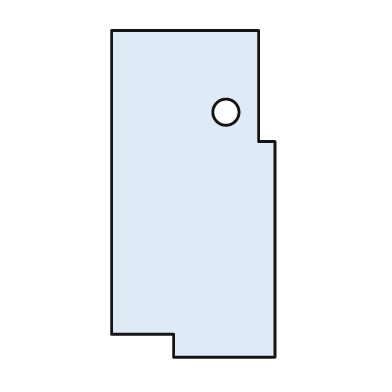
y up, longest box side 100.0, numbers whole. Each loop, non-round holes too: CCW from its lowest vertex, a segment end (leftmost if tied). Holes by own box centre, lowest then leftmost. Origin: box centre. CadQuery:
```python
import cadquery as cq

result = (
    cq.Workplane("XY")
    .moveTo(-6.0, -50.0)
    .lineTo(25.0, -50.0)
    .lineTo(25.0, 16.0)
    .lineTo(20.0, 16.0)
    .lineTo(20.0, 50.0)
    .lineTo(-25.0, 50.0)
    .lineTo(-25.0, -43.0)
    .lineTo(-6.0, -43.0)
    .close()
    .moveTo(10.0, 25.0)
    .circle(4.0)
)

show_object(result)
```